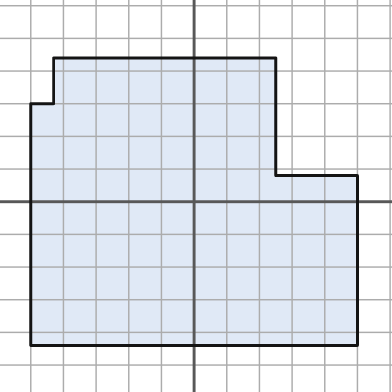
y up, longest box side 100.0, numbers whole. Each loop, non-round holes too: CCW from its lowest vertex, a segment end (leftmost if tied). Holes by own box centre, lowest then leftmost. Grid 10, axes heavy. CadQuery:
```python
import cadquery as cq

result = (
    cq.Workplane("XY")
    .moveTo(-50.0, -44.0)
    .lineTo(50.0, -44.0)
    .lineTo(50.0, 8.0)
    .lineTo(25.0, 8.0)
    .lineTo(25.0, 44.0)
    .lineTo(-43.0, 44.0)
    .lineTo(-43.0, 30.0)
    .lineTo(-50.0, 30.0)
    .close()
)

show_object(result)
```